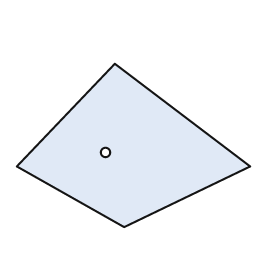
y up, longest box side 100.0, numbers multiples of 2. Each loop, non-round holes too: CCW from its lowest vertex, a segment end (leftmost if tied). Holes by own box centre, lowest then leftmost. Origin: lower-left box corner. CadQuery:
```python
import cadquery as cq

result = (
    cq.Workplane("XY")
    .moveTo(46.0, 0.0)
    .lineTo(100.0, 26.0)
    .lineTo(42.0, 70.0)
    .lineTo(0.0, 26.0)
    .close()
    .moveTo(38.0, 32.0)
    .circle(2.0)
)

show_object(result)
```